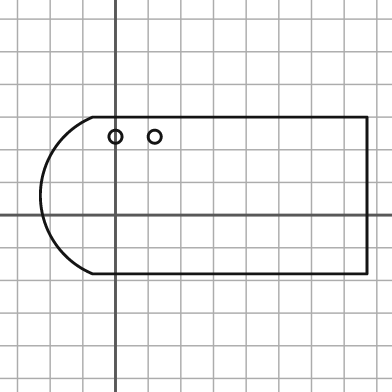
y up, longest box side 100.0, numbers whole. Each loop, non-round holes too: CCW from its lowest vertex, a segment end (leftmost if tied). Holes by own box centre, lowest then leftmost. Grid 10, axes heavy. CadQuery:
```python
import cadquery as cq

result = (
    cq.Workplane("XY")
    .moveTo(-7.0, -18.0)
    .lineTo(77.0, -18.0)
    .lineTo(77.0, 30.0)
    .lineTo(-7.0, 30.0)
    .threePointArc((-23.0, 6.0), (-7.0, -18.0))
    .close()
    .moveTo(0.0, 24.0)
    .circle(2.0)
    .moveTo(12.0, 24.0)
    .circle(2.0)
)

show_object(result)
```